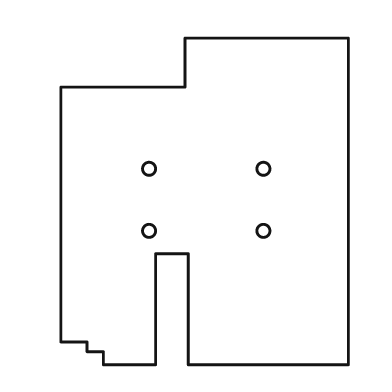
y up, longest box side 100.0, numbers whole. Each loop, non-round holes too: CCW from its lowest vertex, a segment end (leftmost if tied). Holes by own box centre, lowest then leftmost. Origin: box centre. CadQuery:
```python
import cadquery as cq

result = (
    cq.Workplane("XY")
    .moveTo(-31.0, -50.0)
    .lineTo(-15.0, -50.0)
    .lineTo(-15.0, -16.0)
    .lineTo(-5.0, -16.0)
    .lineTo(-5.0, -50.0)
    .lineTo(44.0, -50.0)
    .lineTo(44.0, 50.0)
    .lineTo(-6.0, 50.0)
    .lineTo(-6.0, 35.0)
    .lineTo(-44.0, 35.0)
    .lineTo(-44.0, -43.0)
    .lineTo(-36.0, -43.0)
    .lineTo(-36.0, -46.0)
    .lineTo(-31.0, -46.0)
    .close()
    .moveTo(-17.0, -9.0)
    .circle(2.0)
    .moveTo(18.0, -9.0)
    .circle(2.0)
    .moveTo(-17.0, 10.0)
    .circle(2.0)
    .moveTo(18.0, 10.0)
    .circle(2.0)
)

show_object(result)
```